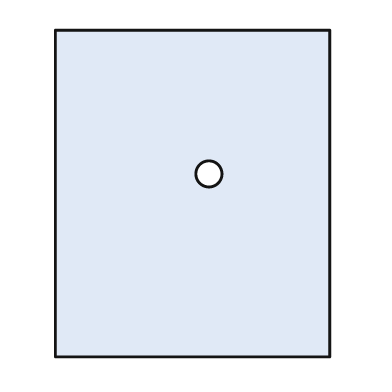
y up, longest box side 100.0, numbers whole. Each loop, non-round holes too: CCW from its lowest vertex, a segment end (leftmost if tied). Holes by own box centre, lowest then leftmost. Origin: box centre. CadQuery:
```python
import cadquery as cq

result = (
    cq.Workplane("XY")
    .moveTo(-42.0, -50.0)
    .lineTo(42.0, -50.0)
    .lineTo(42.0, 50.0)
    .lineTo(-42.0, 50.0)
    .close()
    .moveTo(5.0, 6.0)
    .circle(4.0)
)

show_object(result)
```